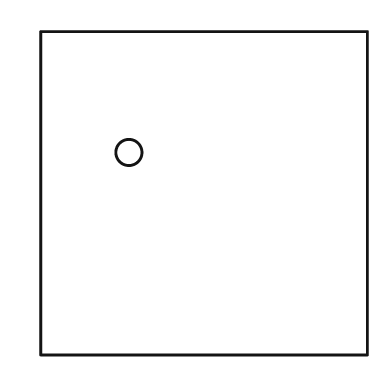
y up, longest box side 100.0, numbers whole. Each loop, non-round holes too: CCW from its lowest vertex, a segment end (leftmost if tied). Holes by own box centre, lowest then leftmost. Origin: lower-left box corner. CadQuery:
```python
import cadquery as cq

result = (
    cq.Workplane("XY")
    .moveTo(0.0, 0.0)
    .lineTo(100.0, 0.0)
    .lineTo(100.0, 99.0)
    .lineTo(0.0, 99.0)
    .close()
    .moveTo(27.0, 62.0)
    .circle(4.0)
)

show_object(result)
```